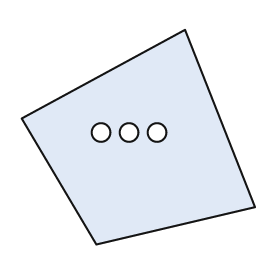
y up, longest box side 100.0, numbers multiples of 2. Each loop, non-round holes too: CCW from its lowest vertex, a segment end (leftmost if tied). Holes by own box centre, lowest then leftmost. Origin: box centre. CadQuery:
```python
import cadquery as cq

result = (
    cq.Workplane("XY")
    .moveTo(-18.0, -46.0)
    .lineTo(50.0, -30.0)
    .lineTo(20.0, 46.0)
    .lineTo(-50.0, 8.0)
    .close()
    .moveTo(-16.0, 2.0)
    .circle(4.0)
    .moveTo(-4.0, 2.0)
    .circle(4.0)
    .moveTo(8.0, 2.0)
    .circle(4.0)
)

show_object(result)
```